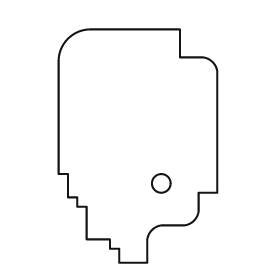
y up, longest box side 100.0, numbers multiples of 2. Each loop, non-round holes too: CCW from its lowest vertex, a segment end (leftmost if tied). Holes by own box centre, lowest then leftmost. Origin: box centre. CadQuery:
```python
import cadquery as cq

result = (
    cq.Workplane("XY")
    .moveTo(-8.0, -50.0)
    .lineTo(4.0, -50.0)
    .lineTo(4.0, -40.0)
    .threePointArc((6.0, -36.0), (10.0, -34.0))
    .lineTo(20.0, -34.0)
    .threePointArc((24.0, -32.0), (26.0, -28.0))
    .lineTo(26.0, -20.0)
    .lineTo(34.0, -20.0)
    .lineTo(34.0, 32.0)
    .threePointArc((32.0, 36.0), (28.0, 38.0))
    .lineTo(18.0, 38.0)
    .lineTo(18.0, 50.0)
    .lineTo(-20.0, 50.0)
    .threePointArc((-30.0, 46.0), (-34.0, 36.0))
    .lineTo(-34.0, -12.0)
    .lineTo(-30.0, -12.0)
    .lineTo(-30.0, -22.0)
    .lineTo(-26.0, -22.0)
    .lineTo(-26.0, -26.0)
    .lineTo(-22.0, -26.0)
    .lineTo(-22.0, -40.0)
    .lineTo(-12.0, -40.0)
    .lineTo(-12.0, -44.0)
    .lineTo(-8.0, -44.0)
    .close()
    .moveTo(10.0, -16.0)
    .circle(4.0)
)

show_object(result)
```